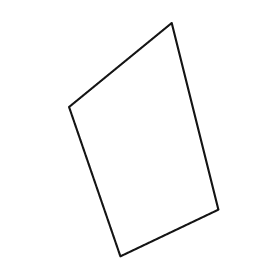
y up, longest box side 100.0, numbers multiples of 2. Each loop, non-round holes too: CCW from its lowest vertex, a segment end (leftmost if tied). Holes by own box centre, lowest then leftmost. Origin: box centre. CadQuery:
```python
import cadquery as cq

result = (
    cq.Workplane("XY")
    .moveTo(-10.0, -50.0)
    .lineTo(32.0, -30.0)
    .lineTo(12.0, 50.0)
    .lineTo(-32.0, 14.0)
    .close()
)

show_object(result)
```